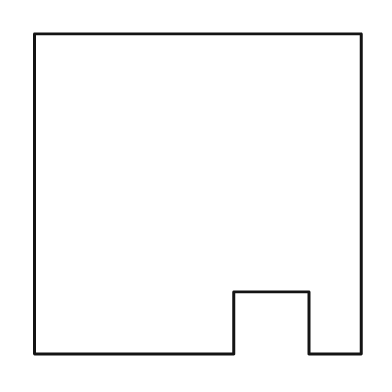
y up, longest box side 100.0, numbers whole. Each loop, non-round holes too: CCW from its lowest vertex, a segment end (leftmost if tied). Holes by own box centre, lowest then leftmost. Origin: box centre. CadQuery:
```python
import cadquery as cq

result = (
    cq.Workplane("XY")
    .moveTo(-50.0, -49.0)
    .lineTo(11.0, -49.0)
    .lineTo(11.0, -30.0)
    .lineTo(34.0, -30.0)
    .lineTo(34.0, -49.0)
    .lineTo(50.0, -49.0)
    .lineTo(50.0, 49.0)
    .lineTo(-50.0, 49.0)
    .close()
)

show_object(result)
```